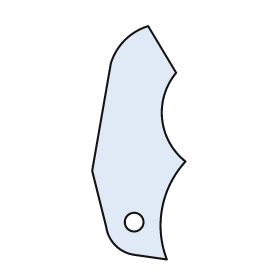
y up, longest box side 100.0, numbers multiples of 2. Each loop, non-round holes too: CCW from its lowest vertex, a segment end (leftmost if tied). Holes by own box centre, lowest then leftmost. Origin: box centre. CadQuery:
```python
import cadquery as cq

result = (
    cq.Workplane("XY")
    .moveTo(12.0, -50.0)
    .threePointArc((10.0, -28.0), (20.0, -8.0))
    .threePointArc((10.0, 10.0), (16.0, 30.0))
    .lineTo(4.0, 50.0)
    .threePointArc((-6.0, 44.0), (-12.0, 34.0))
    .lineTo(-20.0, -12.0)
    .lineTo(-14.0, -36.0)
    .threePointArc((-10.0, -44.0), (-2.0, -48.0))
    .close()
    .moveTo(-2.0, -34.0)
    .circle(4.0)
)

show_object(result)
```